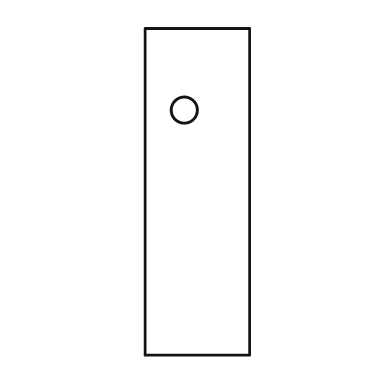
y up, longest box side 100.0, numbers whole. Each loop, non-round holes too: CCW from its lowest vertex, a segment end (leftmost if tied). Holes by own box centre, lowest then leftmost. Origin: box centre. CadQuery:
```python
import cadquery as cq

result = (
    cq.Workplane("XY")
    .moveTo(-16.0, -50.0)
    .lineTo(16.0, -50.0)
    .lineTo(16.0, 50.0)
    .lineTo(-16.0, 50.0)
    .close()
    .moveTo(-4.0, 25.0)
    .circle(4.0)
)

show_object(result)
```